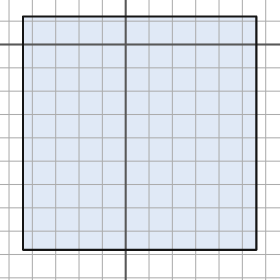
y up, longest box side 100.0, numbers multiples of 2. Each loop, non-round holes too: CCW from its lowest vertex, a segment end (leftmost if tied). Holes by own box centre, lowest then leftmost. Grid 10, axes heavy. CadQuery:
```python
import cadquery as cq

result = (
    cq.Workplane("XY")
    .moveTo(-44.0, -88.0)
    .lineTo(56.0, -88.0)
    .lineTo(56.0, 12.0)
    .lineTo(-44.0, 12.0)
    .close()
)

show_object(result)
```